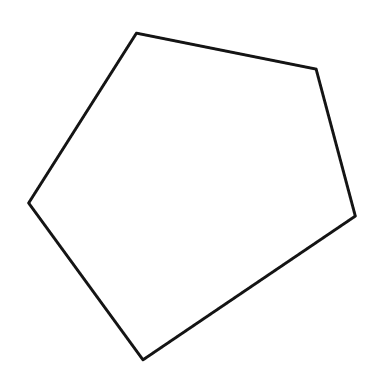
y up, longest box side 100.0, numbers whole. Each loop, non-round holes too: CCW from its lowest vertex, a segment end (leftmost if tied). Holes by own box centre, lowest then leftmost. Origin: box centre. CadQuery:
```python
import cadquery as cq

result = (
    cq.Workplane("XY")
    .moveTo(-15.0, -50.0)
    .lineTo(50.0, -6.0)
    .lineTo(38.0, 39.0)
    .lineTo(-17.0, 50.0)
    .lineTo(-50.0, -2.0)
    .close()
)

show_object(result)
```